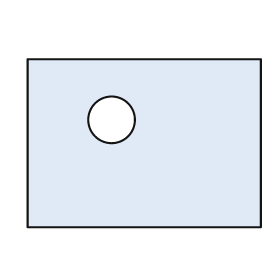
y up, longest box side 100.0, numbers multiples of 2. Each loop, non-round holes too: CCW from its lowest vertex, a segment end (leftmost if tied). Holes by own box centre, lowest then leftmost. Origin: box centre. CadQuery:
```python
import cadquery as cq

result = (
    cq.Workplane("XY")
    .moveTo(-50.0, -36.0)
    .lineTo(50.0, -36.0)
    .lineTo(50.0, 36.0)
    .lineTo(-50.0, 36.0)
    .close()
    .moveTo(-14.0, 10.0)
    .circle(10.0)
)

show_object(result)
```